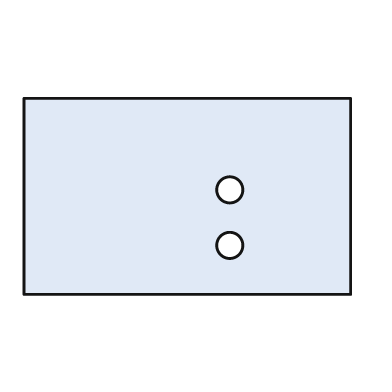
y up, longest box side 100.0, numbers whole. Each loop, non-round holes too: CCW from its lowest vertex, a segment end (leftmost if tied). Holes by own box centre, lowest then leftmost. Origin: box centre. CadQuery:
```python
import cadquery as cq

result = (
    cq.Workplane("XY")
    .moveTo(-50.0, -30.0)
    .lineTo(50.0, -30.0)
    .lineTo(50.0, 30.0)
    .lineTo(-50.0, 30.0)
    .close()
    .moveTo(13.0, -15.0)
    .circle(4.0)
    .moveTo(13.0, 2.0)
    .circle(4.0)
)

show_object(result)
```